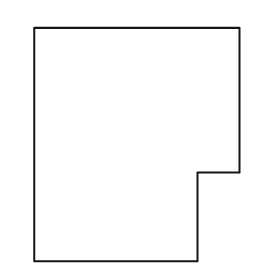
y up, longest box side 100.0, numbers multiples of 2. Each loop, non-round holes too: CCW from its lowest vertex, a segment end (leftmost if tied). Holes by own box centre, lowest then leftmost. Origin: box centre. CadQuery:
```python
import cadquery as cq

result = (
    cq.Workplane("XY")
    .moveTo(-44.0, -50.0)
    .lineTo(26.0, -50.0)
    .lineTo(26.0, -12.0)
    .lineTo(44.0, -12.0)
    .lineTo(44.0, 50.0)
    .lineTo(-44.0, 50.0)
    .close()
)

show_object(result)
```